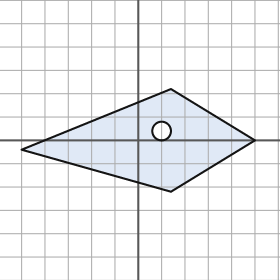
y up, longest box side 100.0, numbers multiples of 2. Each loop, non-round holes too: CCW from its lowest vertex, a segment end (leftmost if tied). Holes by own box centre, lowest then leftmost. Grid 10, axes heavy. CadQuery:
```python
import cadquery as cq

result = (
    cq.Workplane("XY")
    .moveTo(14.0, -22.0)
    .lineTo(50.0, 0.0)
    .lineTo(14.0, 22.0)
    .lineTo(-50.0, -4.0)
    .close()
    .moveTo(10.0, 4.0)
    .circle(4.0)
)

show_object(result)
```